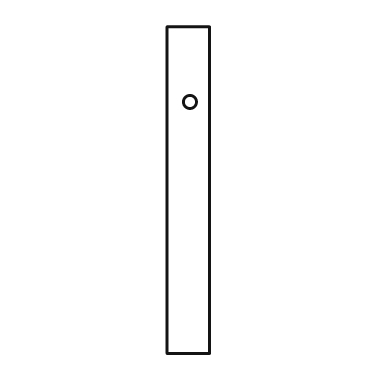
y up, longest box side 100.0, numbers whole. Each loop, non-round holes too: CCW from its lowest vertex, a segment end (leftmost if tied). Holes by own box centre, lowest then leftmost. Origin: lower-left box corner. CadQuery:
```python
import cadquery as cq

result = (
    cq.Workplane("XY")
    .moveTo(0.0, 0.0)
    .lineTo(13.0, 0.0)
    .lineTo(13.0, 100.0)
    .lineTo(0.0, 100.0)
    .close()
    .moveTo(7.0, 77.0)
    .circle(2.0)
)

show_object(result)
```